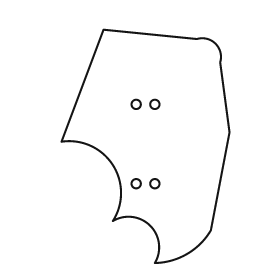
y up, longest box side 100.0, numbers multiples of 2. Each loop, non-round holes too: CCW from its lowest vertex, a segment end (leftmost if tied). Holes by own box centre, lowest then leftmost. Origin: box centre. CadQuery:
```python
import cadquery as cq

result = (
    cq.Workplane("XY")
    .moveTo(4.0, -50.0)
    .threePointArc((18.0, -46.0), (28.0, -36.0))
    .lineTo(36.0, 6.0)
    .lineTo(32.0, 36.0)
    .threePointArc((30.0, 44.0), (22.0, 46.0))
    .lineTo(-18.0, 50.0)
    .lineTo(-36.0, 2.0)
    .threePointArc((-14.0, -8.0), (-14.0, -32.0))
    .threePointArc((2.0, -34.0), (4.0, -50.0))
    .close()
    .moveTo(-4.0, -16.0)
    .circle(2.0)
    .moveTo(4.0, -16.0)
    .circle(2.0)
    .moveTo(-4.0, 18.0)
    .circle(2.0)
    .moveTo(4.0, 18.0)
    .circle(2.0)
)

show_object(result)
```